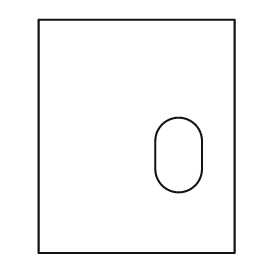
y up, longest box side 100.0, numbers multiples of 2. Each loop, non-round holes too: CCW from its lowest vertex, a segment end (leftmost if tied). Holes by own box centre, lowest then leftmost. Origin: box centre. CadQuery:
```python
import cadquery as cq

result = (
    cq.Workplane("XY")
    .moveTo(-42.0, -50.0)
    .lineTo(42.0, -50.0)
    .lineTo(42.0, 50.0)
    .lineTo(-42.0, 50.0)
    .close()
    .moveTo(8.0, -14.0)
    .threePointArc((18.0, -24.0), (28.0, -14.0))
    .lineTo(28.0, -2.0)
    .threePointArc((18.0, 8.0), (8.0, -2.0))
    .close()
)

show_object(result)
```